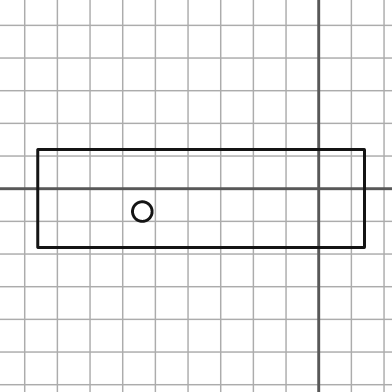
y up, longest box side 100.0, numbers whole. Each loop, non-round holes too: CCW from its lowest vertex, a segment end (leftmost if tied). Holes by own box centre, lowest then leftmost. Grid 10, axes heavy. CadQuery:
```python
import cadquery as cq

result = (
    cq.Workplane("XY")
    .moveTo(-86.0, -18.0)
    .lineTo(14.0, -18.0)
    .lineTo(14.0, 12.0)
    .lineTo(-86.0, 12.0)
    .close()
    .moveTo(-54.0, -7.0)
    .circle(3.0)
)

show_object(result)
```